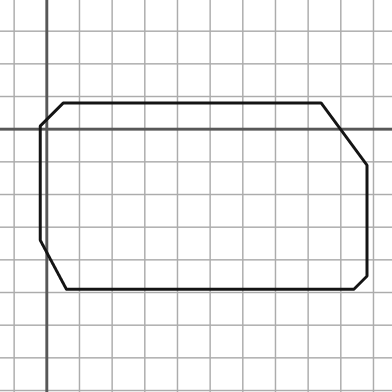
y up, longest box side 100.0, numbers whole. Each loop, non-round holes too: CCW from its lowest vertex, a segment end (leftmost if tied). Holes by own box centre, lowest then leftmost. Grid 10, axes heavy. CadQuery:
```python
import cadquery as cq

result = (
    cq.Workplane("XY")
    .moveTo(6.0, -49.0)
    .lineTo(94.0, -49.0)
    .lineTo(98.0, -45.0)
    .lineTo(98.0, -11.0)
    .lineTo(84.0, 8.0)
    .lineTo(5.0, 8.0)
    .lineTo(-2.0, 1.0)
    .lineTo(-2.0, -34.0)
    .close()
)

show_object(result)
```